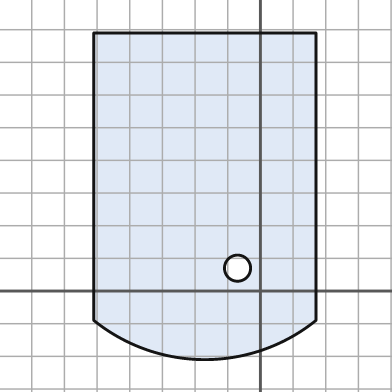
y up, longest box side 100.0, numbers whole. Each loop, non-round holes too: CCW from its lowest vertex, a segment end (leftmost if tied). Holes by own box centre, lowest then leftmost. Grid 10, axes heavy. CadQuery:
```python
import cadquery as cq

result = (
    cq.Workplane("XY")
    .moveTo(-51.0, -9.0)
    .threePointArc((-17.0, -21.0), (17.0, -9.0))
    .lineTo(17.0, 79.0)
    .lineTo(-51.0, 79.0)
    .close()
    .moveTo(-7.0, 7.0)
    .circle(4.0)
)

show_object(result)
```